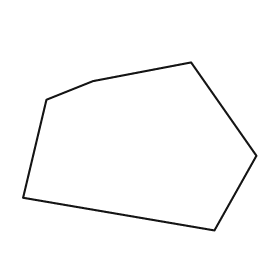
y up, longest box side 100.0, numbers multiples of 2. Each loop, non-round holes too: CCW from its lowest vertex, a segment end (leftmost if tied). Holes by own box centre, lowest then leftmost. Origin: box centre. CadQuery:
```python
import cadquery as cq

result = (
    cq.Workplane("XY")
    .moveTo(32.0, -36.0)
    .lineTo(50.0, -4.0)
    .lineTo(22.0, 36.0)
    .lineTo(-20.0, 28.0)
    .lineTo(-40.0, 20.0)
    .lineTo(-50.0, -22.0)
    .close()
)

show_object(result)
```